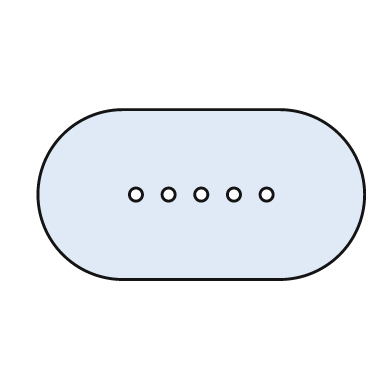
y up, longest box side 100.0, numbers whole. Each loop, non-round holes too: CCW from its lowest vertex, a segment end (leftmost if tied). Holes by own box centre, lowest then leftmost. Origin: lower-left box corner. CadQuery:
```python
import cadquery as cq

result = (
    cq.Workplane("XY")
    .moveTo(26.0, 0.0)
    .lineTo(74.0, 0.0)
    .threePointArc((100.0, 26.0), (74.0, 52.0))
    .lineTo(26.0, 52.0)
    .threePointArc((0.0, 26.0), (26.0, 0.0))
    .close()
    .moveTo(30.0, 26.0)
    .circle(2.0)
    .moveTo(40.0, 26.0)
    .circle(2.0)
    .moveTo(50.0, 26.0)
    .circle(2.0)
    .moveTo(60.0, 26.0)
    .circle(2.0)
    .moveTo(70.0, 26.0)
    .circle(2.0)
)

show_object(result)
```